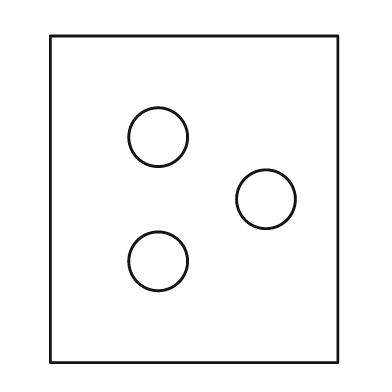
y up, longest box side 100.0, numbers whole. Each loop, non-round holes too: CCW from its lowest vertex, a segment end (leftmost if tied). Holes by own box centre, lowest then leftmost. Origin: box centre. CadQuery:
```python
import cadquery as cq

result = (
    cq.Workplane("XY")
    .moveTo(-44.0, -50.0)
    .lineTo(44.0, -50.0)
    .lineTo(44.0, 50.0)
    .lineTo(-44.0, 50.0)
    .close()
    .moveTo(-11.0, -19.0)
    .circle(9.0)
    .moveTo(22.0, 0.0)
    .circle(9.0)
    .moveTo(-11.0, 19.0)
    .circle(9.0)
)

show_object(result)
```